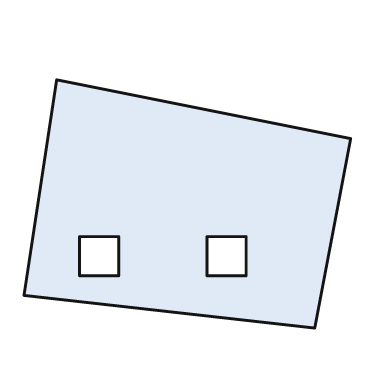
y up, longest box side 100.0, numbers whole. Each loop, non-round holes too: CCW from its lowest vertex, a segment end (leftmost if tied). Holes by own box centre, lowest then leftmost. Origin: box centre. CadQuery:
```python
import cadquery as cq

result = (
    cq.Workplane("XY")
    .moveTo(39.0, -38.0)
    .lineTo(50.0, 20.0)
    .lineTo(-40.0, 38.0)
    .lineTo(-50.0, -28.0)
    .close()
    .moveTo(-33.0, -22.0)
    .lineTo(-21.0, -22.0)
    .lineTo(-21.0, -10.0)
    .lineTo(-33.0, -10.0)
    .close()
    .moveTo(6.0, -22.0)
    .lineTo(18.0, -22.0)
    .lineTo(18.0, -10.0)
    .lineTo(6.0, -10.0)
    .close()
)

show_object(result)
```